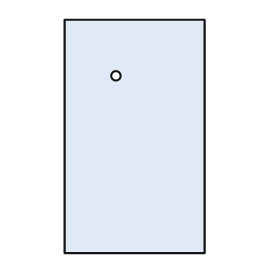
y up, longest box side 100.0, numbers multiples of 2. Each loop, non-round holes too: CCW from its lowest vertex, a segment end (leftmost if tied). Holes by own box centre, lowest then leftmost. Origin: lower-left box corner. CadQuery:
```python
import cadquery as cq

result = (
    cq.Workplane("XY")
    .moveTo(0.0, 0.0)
    .lineTo(60.0, 0.0)
    .lineTo(60.0, 100.0)
    .lineTo(0.0, 100.0)
    .close()
    .moveTo(22.0, 76.0)
    .circle(2.0)
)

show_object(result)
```